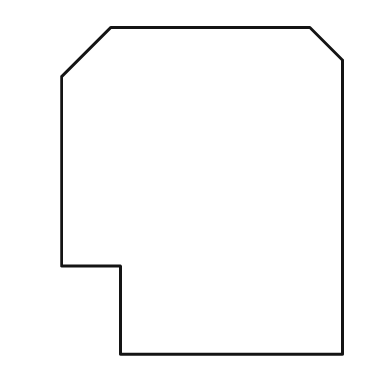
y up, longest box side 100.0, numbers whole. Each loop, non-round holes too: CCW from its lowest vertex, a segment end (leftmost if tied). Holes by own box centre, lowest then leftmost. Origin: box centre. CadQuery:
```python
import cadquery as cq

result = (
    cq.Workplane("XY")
    .moveTo(-25.0, -50.0)
    .lineTo(43.0, -50.0)
    .lineTo(43.0, 40.0)
    .lineTo(33.0, 50.0)
    .lineTo(-28.0, 50.0)
    .lineTo(-43.0, 35.0)
    .lineTo(-43.0, -23.0)
    .lineTo(-25.0, -23.0)
    .close()
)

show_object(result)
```